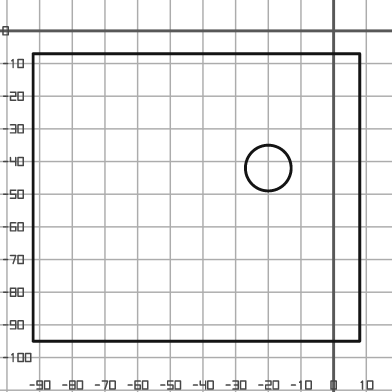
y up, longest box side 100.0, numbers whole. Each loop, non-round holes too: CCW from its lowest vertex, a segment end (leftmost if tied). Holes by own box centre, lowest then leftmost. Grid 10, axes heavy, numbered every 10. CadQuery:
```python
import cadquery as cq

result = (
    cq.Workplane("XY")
    .moveTo(-92.0, -95.0)
    .lineTo(8.0, -95.0)
    .lineTo(8.0, -7.0)
    .lineTo(-92.0, -7.0)
    .close()
    .moveTo(-20.0, -42.0)
    .circle(7.0)
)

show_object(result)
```